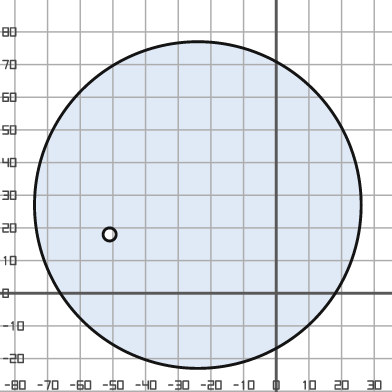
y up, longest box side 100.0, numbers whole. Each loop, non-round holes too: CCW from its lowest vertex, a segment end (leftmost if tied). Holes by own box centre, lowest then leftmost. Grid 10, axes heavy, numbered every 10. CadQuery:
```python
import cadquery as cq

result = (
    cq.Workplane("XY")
    .moveTo(-24.0, 27.0)
    .circle(50.0)
    .moveTo(-51.0, 18.0)
    .circle(2.0)
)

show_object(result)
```